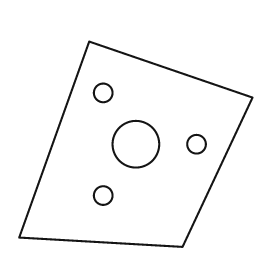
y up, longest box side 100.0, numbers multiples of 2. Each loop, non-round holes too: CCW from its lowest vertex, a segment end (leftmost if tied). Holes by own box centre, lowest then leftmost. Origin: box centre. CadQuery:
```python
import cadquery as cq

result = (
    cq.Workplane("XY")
    .moveTo(20.0, -44.0)
    .lineTo(50.0, 20.0)
    .lineTo(-20.0, 44.0)
    .lineTo(-50.0, -40.0)
    .close()
    .moveTo(-14.0, -22.0)
    .circle(4.0)
    .moveTo(0.0, 0.0)
    .circle(10.0)
    .moveTo(26.0, 0.0)
    .circle(4.0)
    .moveTo(-14.0, 22.0)
    .circle(4.0)
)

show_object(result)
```